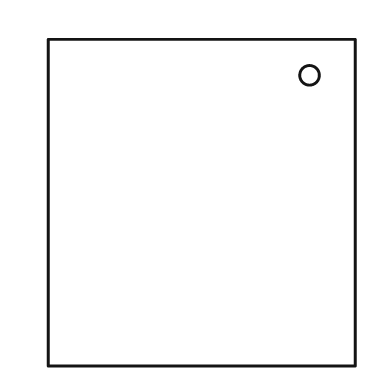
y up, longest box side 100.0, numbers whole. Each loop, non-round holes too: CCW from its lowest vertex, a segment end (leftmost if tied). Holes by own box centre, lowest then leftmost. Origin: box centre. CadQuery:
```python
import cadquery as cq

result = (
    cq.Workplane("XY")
    .moveTo(-47.0, -50.0)
    .lineTo(47.0, -50.0)
    .lineTo(47.0, 50.0)
    .lineTo(-47.0, 50.0)
    .close()
    .moveTo(33.0, 39.0)
    .circle(3.0)
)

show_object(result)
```